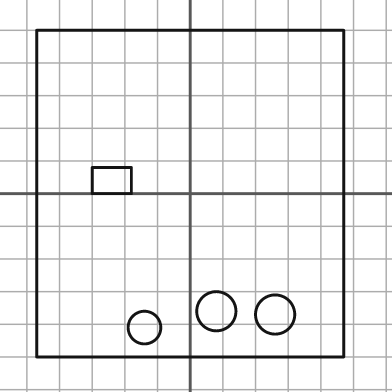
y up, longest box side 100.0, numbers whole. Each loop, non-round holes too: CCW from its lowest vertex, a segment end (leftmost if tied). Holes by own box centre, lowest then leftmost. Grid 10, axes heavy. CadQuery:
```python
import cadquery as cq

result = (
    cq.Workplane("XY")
    .moveTo(-47.0, -50.0)
    .lineTo(47.0, -50.0)
    .lineTo(47.0, 50.0)
    .lineTo(-47.0, 50.0)
    .close()
    .moveTo(-14.0, -41.0)
    .circle(5.0)
    .moveTo(26.0, -37.0)
    .circle(6.0)
    .moveTo(8.0, -36.0)
    .circle(6.0)
    .moveTo(-30.0, 0.0)
    .lineTo(-18.0, 0.0)
    .lineTo(-18.0, 8.0)
    .lineTo(-30.0, 8.0)
    .close()
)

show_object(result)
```